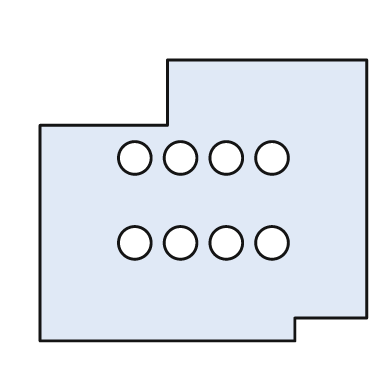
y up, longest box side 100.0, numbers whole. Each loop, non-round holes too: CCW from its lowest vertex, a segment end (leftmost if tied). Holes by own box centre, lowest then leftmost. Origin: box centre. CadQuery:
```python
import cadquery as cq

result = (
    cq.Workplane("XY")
    .moveTo(-50.0, -43.0)
    .lineTo(28.0, -43.0)
    .lineTo(28.0, -36.0)
    .lineTo(50.0, -36.0)
    .lineTo(50.0, 43.0)
    .lineTo(-11.0, 43.0)
    .lineTo(-11.0, 23.0)
    .lineTo(-50.0, 23.0)
    .close()
    .moveTo(-21.0, -13.0)
    .circle(5.0)
    .moveTo(-7.0, -13.0)
    .circle(5.0)
    .moveTo(7.0, -13.0)
    .circle(5.0)
    .moveTo(21.0, -13.0)
    .circle(5.0)
    .moveTo(-21.0, 13.0)
    .circle(5.0)
    .moveTo(-7.0, 13.0)
    .circle(5.0)
    .moveTo(7.0, 13.0)
    .circle(5.0)
    .moveTo(21.0, 13.0)
    .circle(5.0)
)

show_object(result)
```